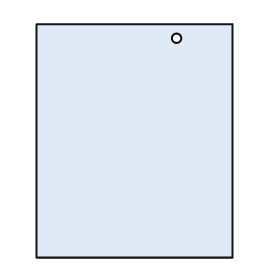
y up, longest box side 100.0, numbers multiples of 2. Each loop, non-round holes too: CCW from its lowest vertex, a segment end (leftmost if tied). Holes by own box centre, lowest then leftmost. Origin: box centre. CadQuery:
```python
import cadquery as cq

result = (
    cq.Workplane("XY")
    .moveTo(-42.0, -50.0)
    .lineTo(42.0, -50.0)
    .lineTo(42.0, 50.0)
    .lineTo(-42.0, 50.0)
    .close()
    .moveTo(18.0, 44.0)
    .circle(2.0)
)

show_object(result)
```